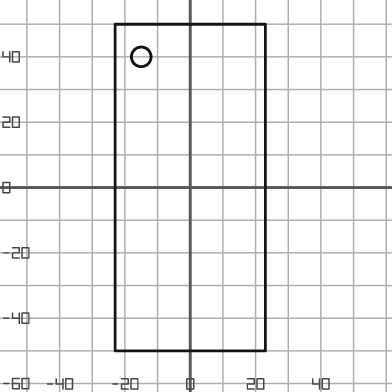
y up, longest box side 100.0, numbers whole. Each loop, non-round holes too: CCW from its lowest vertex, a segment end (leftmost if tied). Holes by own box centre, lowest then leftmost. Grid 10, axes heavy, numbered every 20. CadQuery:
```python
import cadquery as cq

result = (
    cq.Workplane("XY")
    .moveTo(-23.0, -50.0)
    .lineTo(23.0, -50.0)
    .lineTo(23.0, 50.0)
    .lineTo(-23.0, 50.0)
    .close()
    .moveTo(-15.0, 40.0)
    .circle(3.0)
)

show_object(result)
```